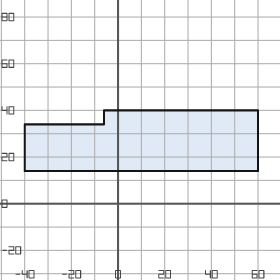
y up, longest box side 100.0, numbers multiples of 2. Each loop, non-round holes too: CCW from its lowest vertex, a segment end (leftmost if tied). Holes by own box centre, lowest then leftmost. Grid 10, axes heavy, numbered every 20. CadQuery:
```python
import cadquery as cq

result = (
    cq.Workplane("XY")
    .moveTo(-40.0, 14.0)
    .lineTo(60.0, 14.0)
    .lineTo(60.0, 40.0)
    .lineTo(-6.0, 40.0)
    .lineTo(-6.0, 34.0)
    .lineTo(-40.0, 34.0)
    .close()
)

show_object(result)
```